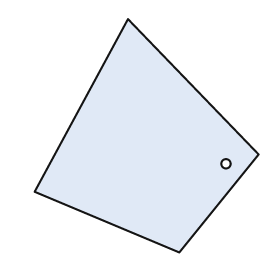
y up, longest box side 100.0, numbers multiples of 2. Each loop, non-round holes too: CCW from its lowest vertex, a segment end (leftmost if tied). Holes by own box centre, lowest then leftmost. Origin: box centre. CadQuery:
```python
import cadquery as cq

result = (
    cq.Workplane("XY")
    .moveTo(14.0, -50.0)
    .lineTo(48.0, -8.0)
    .lineTo(-8.0, 50.0)
    .lineTo(-48.0, -24.0)
    .close()
    .moveTo(34.0, -12.0)
    .circle(2.0)
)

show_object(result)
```